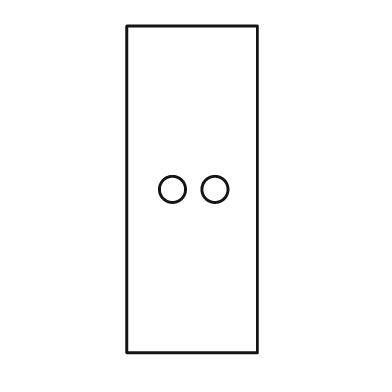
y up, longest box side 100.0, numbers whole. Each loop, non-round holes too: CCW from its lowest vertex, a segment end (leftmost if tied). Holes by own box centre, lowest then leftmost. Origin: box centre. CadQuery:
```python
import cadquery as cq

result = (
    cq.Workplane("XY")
    .moveTo(-20.0, -50.0)
    .lineTo(20.0, -50.0)
    .lineTo(20.0, 50.0)
    .lineTo(-20.0, 50.0)
    .close()
    .moveTo(-6.0, 0.0)
    .circle(4.0)
    .moveTo(7.0, 0.0)
    .circle(4.0)
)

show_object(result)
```